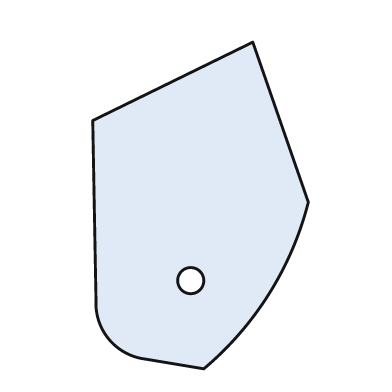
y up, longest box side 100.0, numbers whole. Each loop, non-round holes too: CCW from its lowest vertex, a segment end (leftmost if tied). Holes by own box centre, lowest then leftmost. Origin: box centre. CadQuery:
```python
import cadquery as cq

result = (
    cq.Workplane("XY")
    .moveTo(1.0, -50.0)
    .threePointArc((21.0, -27.0), (33.0, 1.0))
    .lineTo(16.0, 50.0)
    .lineTo(-33.0, 26.0)
    .lineTo(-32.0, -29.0)
    .threePointArc((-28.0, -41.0), (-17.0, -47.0))
    .close()
    .moveTo(-3.0, -23.0)
    .circle(4.0)
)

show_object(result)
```